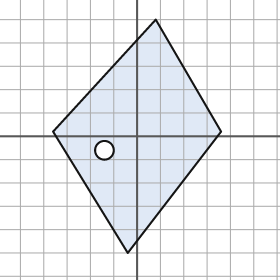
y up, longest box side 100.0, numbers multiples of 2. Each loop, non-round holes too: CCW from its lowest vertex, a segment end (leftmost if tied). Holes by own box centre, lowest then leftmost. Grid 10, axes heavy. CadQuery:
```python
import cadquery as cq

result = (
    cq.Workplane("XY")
    .moveTo(-4.0, -50.0)
    .lineTo(36.0, 2.0)
    .lineTo(8.0, 50.0)
    .lineTo(-36.0, 2.0)
    .close()
    .moveTo(-14.0, -6.0)
    .circle(4.0)
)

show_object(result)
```